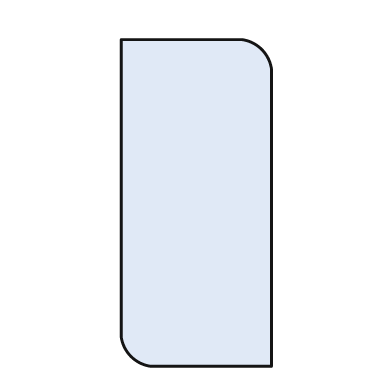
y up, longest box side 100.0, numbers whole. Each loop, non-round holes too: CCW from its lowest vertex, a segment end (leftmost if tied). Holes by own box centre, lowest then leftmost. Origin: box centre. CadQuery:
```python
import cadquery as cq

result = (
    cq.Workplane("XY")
    .moveTo(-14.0, -50.0)
    .lineTo(23.0, -50.0)
    .lineTo(23.0, 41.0)
    .threePointArc((20.0, 47.0), (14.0, 50.0))
    .lineTo(-23.0, 50.0)
    .lineTo(-23.0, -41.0)
    .threePointArc((-20.0, -47.0), (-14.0, -50.0))
    .close()
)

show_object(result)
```